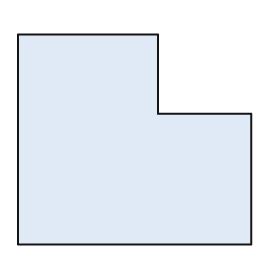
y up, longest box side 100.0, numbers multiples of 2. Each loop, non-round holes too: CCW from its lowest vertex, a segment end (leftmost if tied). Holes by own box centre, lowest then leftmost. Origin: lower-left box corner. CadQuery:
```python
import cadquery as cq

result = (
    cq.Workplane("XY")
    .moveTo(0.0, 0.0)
    .lineTo(100.0, 0.0)
    .lineTo(100.0, 56.0)
    .lineTo(60.0, 56.0)
    .lineTo(60.0, 90.0)
    .lineTo(0.0, 90.0)
    .close()
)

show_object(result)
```